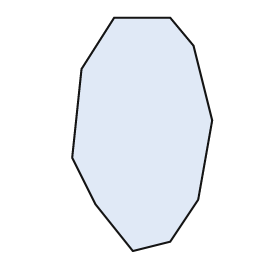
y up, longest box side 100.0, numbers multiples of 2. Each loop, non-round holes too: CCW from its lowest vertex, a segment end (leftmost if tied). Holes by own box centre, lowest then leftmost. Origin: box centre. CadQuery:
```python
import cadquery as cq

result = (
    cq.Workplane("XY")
    .moveTo(-4.0, -50.0)
    .lineTo(12.0, -46.0)
    .lineTo(24.0, -28.0)
    .lineTo(30.0, 6.0)
    .lineTo(22.0, 38.0)
    .lineTo(12.0, 50.0)
    .lineTo(-12.0, 50.0)
    .lineTo(-26.0, 28.0)
    .lineTo(-30.0, -10.0)
    .lineTo(-20.0, -30.0)
    .close()
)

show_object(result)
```